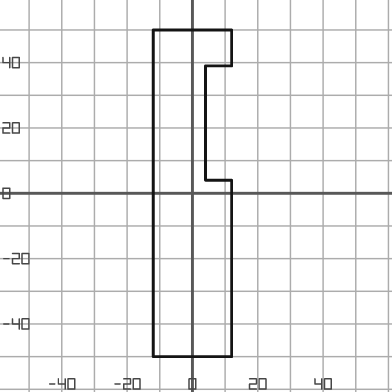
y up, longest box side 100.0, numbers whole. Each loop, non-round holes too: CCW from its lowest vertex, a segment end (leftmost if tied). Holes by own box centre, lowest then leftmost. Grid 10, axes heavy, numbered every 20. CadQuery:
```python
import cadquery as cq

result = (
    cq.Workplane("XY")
    .moveTo(-12.0, -50.0)
    .lineTo(12.0, -50.0)
    .lineTo(12.0, 4.0)
    .lineTo(4.0, 4.0)
    .lineTo(4.0, 39.0)
    .lineTo(12.0, 39.0)
    .lineTo(12.0, 50.0)
    .lineTo(-12.0, 50.0)
    .close()
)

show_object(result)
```